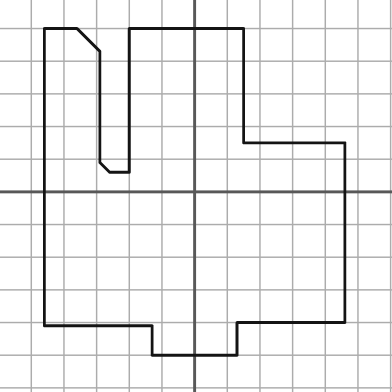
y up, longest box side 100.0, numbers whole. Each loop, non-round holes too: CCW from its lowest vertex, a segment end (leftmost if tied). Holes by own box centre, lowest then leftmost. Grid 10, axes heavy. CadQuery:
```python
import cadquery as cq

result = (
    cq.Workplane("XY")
    .moveTo(-13.0, -50.0)
    .lineTo(13.0, -50.0)
    .lineTo(13.0, -40.0)
    .lineTo(46.0, -40.0)
    .lineTo(46.0, 15.0)
    .lineTo(15.0, 15.0)
    .lineTo(15.0, 50.0)
    .lineTo(-20.0, 50.0)
    .lineTo(-20.0, 6.0)
    .lineTo(-26.0, 6.0)
    .lineTo(-29.0, 9.0)
    .lineTo(-29.0, 43.0)
    .lineTo(-36.0, 50.0)
    .lineTo(-46.0, 50.0)
    .lineTo(-46.0, -41.0)
    .lineTo(-13.0, -41.0)
    .close()
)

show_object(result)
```